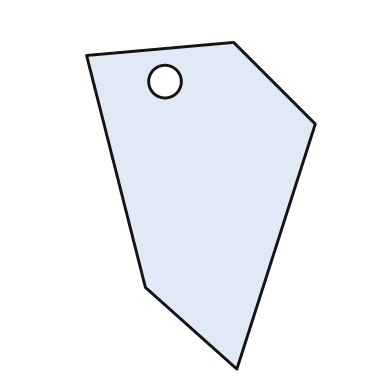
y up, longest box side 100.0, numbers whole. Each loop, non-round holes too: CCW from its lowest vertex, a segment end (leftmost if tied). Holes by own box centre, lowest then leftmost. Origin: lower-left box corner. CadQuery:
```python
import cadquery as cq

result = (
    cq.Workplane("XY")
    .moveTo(46.0, 0.0)
    .lineTo(70.0, 75.0)
    .lineTo(45.0, 100.0)
    .lineTo(0.0, 96.0)
    .lineTo(18.0, 25.0)
    .close()
    .moveTo(24.0, 88.0)
    .circle(5.0)
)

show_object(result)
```